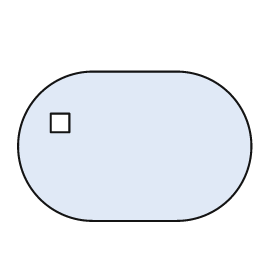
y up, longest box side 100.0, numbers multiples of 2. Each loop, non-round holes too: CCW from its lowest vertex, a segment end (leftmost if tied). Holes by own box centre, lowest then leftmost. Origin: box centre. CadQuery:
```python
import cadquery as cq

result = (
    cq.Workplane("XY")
    .moveTo(-18.0, -32.0)
    .lineTo(18.0, -32.0)
    .threePointArc((50.0, 0.0), (18.0, 32.0))
    .lineTo(-18.0, 32.0)
    .threePointArc((-50.0, 0.0), (-18.0, -32.0))
    .close()
    .moveTo(-36.0, 6.0)
    .lineTo(-28.0, 6.0)
    .lineTo(-28.0, 14.0)
    .lineTo(-36.0, 14.0)
    .close()
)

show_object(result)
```